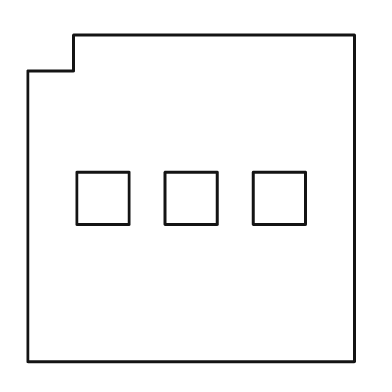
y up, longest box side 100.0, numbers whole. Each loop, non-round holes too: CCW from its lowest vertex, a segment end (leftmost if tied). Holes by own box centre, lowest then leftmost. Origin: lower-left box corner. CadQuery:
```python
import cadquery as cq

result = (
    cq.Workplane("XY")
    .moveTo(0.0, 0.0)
    .lineTo(100.0, 0.0)
    .lineTo(100.0, 100.0)
    .lineTo(14.0, 100.0)
    .lineTo(14.0, 89.0)
    .lineTo(0.0, 89.0)
    .close()
    .moveTo(15.0, 42.0)
    .lineTo(31.0, 42.0)
    .lineTo(31.0, 58.0)
    .lineTo(15.0, 58.0)
    .close()
    .moveTo(42.0, 42.0)
    .lineTo(58.0, 42.0)
    .lineTo(58.0, 58.0)
    .lineTo(42.0, 58.0)
    .close()
    .moveTo(69.0, 42.0)
    .lineTo(85.0, 42.0)
    .lineTo(85.0, 58.0)
    .lineTo(69.0, 58.0)
    .close()
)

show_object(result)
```